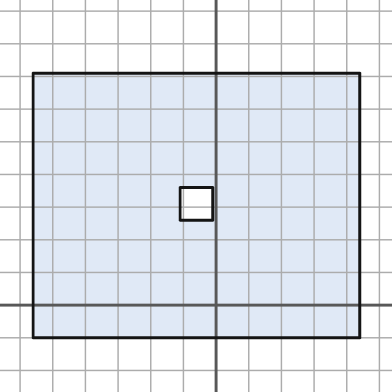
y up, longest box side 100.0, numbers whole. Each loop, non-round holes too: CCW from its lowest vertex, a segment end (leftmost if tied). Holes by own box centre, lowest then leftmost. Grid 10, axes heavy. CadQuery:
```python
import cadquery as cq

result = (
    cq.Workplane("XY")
    .moveTo(-56.0, -10.0)
    .lineTo(44.0, -10.0)
    .lineTo(44.0, 71.0)
    .lineTo(-56.0, 71.0)
    .close()
    .moveTo(-11.0, 26.0)
    .lineTo(-1.0, 26.0)
    .lineTo(-1.0, 36.0)
    .lineTo(-11.0, 36.0)
    .close()
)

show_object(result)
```